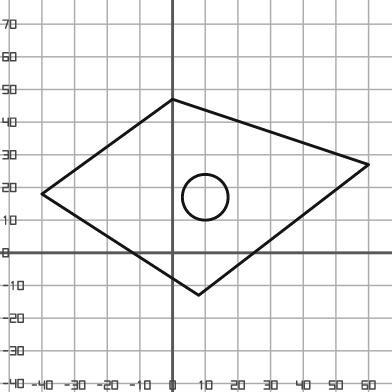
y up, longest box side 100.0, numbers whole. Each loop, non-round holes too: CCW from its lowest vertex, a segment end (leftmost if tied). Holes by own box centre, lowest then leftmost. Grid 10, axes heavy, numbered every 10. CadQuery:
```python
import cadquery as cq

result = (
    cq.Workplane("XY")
    .moveTo(8.0, -13.0)
    .lineTo(60.0, 27.0)
    .lineTo(0.0, 47.0)
    .lineTo(-40.0, 18.0)
    .close()
    .moveTo(10.0, 17.0)
    .circle(7.0)
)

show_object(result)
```